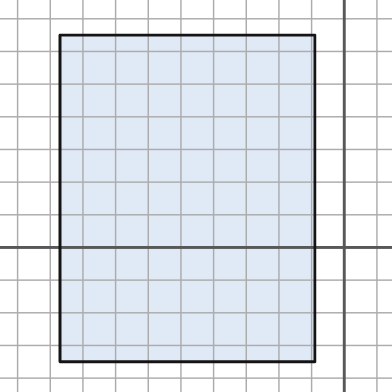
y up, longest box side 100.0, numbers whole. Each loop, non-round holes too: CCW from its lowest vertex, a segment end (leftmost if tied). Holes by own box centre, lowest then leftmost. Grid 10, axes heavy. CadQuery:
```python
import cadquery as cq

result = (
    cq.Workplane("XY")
    .moveTo(-87.0, -35.0)
    .lineTo(-9.0, -35.0)
    .lineTo(-9.0, 65.0)
    .lineTo(-87.0, 65.0)
    .close()
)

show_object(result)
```